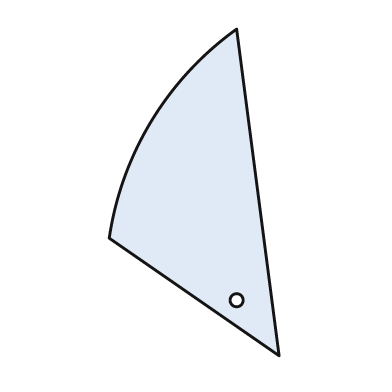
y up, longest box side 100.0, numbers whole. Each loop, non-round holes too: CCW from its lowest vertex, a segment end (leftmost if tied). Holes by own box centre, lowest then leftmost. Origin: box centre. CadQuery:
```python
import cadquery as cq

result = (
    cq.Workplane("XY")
    .moveTo(26.0, -50.0)
    .lineTo(13.0, 50.0)
    .threePointArc((-13.0, 22.0), (-26.0, -14.0))
    .close()
    .moveTo(13.0, -33.0)
    .circle(2.0)
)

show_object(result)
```